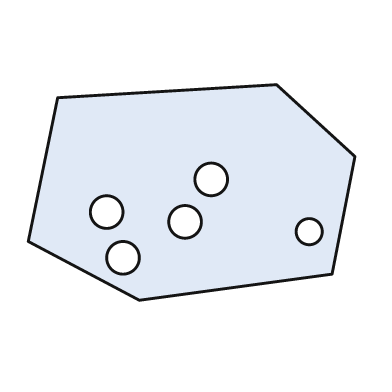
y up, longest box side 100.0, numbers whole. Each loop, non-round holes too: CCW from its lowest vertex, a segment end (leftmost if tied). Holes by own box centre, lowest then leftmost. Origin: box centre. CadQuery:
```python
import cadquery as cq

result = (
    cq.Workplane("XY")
    .moveTo(-16.0, -33.0)
    .lineTo(43.0, -25.0)
    .lineTo(50.0, 11.0)
    .lineTo(26.0, 33.0)
    .lineTo(-41.0, 29.0)
    .lineTo(-50.0, -15.0)
    .close()
    .moveTo(-21.0, -20.0)
    .circle(5.0)
    .moveTo(36.0, -12.0)
    .circle(4.0)
    .moveTo(-2.0, -9.0)
    .circle(5.0)
    .moveTo(-26.0, -6.0)
    .circle(5.0)
    .moveTo(6.0, 4.0)
    .circle(5.0)
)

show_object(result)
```